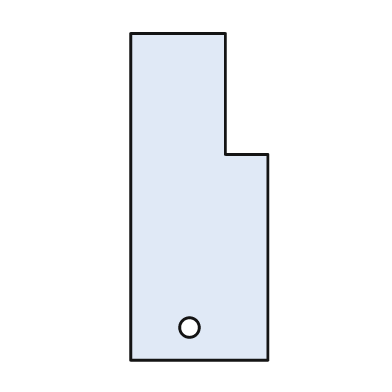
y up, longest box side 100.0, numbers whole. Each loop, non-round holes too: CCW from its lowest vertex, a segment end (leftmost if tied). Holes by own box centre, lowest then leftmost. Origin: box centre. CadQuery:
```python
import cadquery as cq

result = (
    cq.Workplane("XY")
    .moveTo(-21.0, -50.0)
    .lineTo(21.0, -50.0)
    .lineTo(21.0, 13.0)
    .lineTo(8.0, 13.0)
    .lineTo(8.0, 50.0)
    .lineTo(-21.0, 50.0)
    .close()
    .moveTo(-3.0, -40.0)
    .circle(3.0)
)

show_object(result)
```